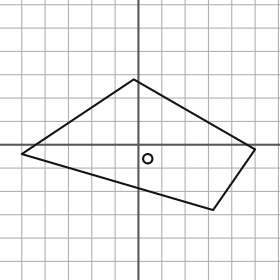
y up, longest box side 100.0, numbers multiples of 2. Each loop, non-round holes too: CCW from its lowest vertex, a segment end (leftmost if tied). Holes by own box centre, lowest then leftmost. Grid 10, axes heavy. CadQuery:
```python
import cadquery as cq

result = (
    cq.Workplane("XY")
    .moveTo(32.0, -28.0)
    .lineTo(50.0, -2.0)
    .lineTo(-2.0, 28.0)
    .lineTo(-50.0, -4.0)
    .close()
    .moveTo(4.0, -6.0)
    .circle(2.0)
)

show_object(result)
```